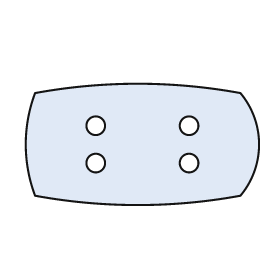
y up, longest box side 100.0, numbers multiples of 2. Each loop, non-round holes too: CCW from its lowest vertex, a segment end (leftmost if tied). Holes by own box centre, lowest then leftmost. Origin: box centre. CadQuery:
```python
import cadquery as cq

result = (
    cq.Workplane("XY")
    .moveTo(-46.0, -22.0)
    .threePointArc((-2.0, -26.0), (42.0, -22.0))
    .threePointArc((50.0, 0.0), (42.0, 22.0))
    .threePointArc((-2.0, 26.0), (-46.0, 22.0))
    .threePointArc((-50.0, 0.0), (-46.0, -22.0))
    .close()
    .moveTo(-20.0, -8.0)
    .circle(4.0)
    .moveTo(20.0, -8.0)
    .circle(4.0)
    .moveTo(-20.0, 8.0)
    .circle(4.0)
    .moveTo(20.0, 8.0)
    .circle(4.0)
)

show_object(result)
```